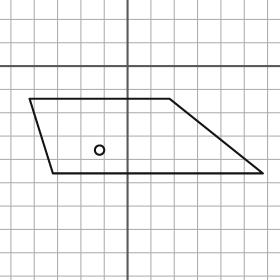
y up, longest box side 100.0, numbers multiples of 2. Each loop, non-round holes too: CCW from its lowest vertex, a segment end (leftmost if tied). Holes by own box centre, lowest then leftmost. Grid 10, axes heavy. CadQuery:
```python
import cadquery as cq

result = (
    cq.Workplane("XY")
    .moveTo(-32.0, -46.0)
    .lineTo(58.0, -46.0)
    .lineTo(18.0, -14.0)
    .lineTo(-42.0, -14.0)
    .close()
    .moveTo(-12.0, -36.0)
    .circle(2.0)
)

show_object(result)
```